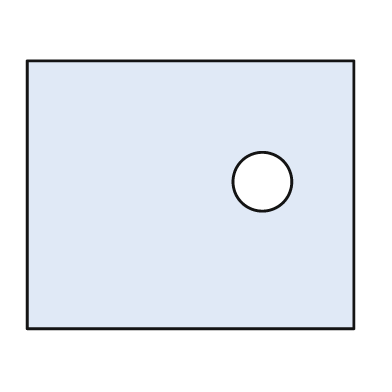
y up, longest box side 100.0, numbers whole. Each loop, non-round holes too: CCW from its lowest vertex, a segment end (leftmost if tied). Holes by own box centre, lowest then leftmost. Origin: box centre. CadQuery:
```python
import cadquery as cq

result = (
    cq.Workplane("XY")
    .moveTo(-50.0, -41.0)
    .lineTo(50.0, -41.0)
    .lineTo(50.0, 41.0)
    .lineTo(-50.0, 41.0)
    .close()
    .moveTo(22.0, 4.0)
    .circle(9.0)
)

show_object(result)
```